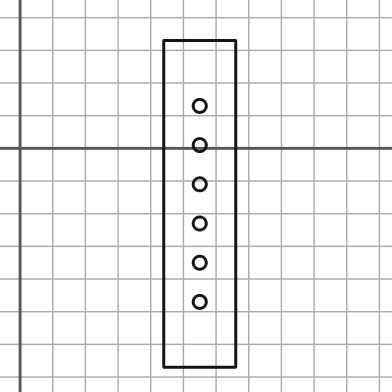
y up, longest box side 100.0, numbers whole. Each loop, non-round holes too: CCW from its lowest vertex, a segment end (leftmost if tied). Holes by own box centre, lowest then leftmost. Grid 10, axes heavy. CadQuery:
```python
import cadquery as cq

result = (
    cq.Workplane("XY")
    .moveTo(44.0, -67.0)
    .lineTo(66.0, -67.0)
    .lineTo(66.0, 33.0)
    .lineTo(44.0, 33.0)
    .close()
    .moveTo(55.0, -47.0)
    .circle(2.0)
    .moveTo(55.0, -35.0)
    .circle(2.0)
    .moveTo(55.0, -23.0)
    .circle(2.0)
    .moveTo(55.0, -11.0)
    .circle(2.0)
    .moveTo(55.0, 1.0)
    .circle(2.0)
    .moveTo(55.0, 13.0)
    .circle(2.0)
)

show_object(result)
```